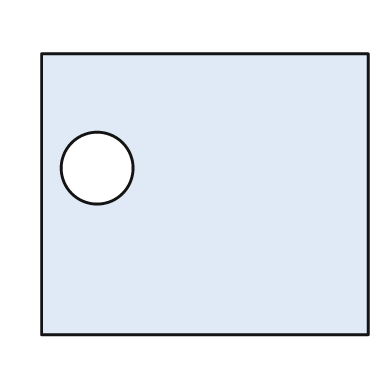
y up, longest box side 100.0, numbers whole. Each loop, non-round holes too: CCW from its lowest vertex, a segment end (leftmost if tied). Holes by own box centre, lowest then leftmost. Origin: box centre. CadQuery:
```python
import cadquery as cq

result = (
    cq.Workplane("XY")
    .moveTo(-50.0, -43.0)
    .lineTo(50.0, -43.0)
    .lineTo(50.0, 43.0)
    .lineTo(-50.0, 43.0)
    .close()
    .moveTo(-33.0, 8.0)
    .circle(11.0)
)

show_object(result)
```